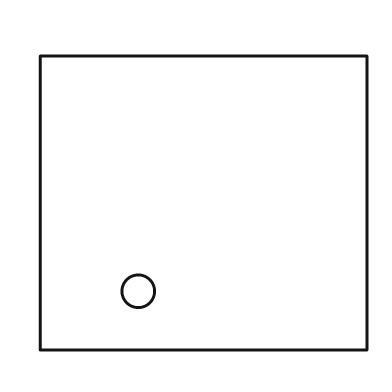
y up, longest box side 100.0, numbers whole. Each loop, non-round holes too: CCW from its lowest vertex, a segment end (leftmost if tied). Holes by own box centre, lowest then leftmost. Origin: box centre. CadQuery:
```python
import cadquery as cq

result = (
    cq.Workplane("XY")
    .moveTo(-50.0, -45.0)
    .lineTo(50.0, -45.0)
    .lineTo(50.0, 45.0)
    .lineTo(-50.0, 45.0)
    .close()
    .moveTo(-20.0, -27.0)
    .circle(5.0)
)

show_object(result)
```